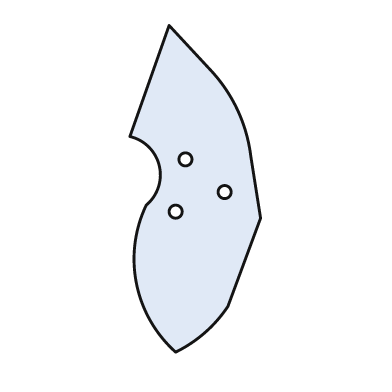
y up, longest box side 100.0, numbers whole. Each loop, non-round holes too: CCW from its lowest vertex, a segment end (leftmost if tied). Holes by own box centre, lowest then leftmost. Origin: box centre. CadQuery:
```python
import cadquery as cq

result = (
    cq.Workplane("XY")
    .moveTo(-6.0, -50.0)
    .threePointArc((3.0, -44.0), (10.0, -36.0))
    .lineTo(20.0, -9.0)
    .lineTo(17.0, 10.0)
    .threePointArc((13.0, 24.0), (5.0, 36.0))
    .lineTo(-8.0, 50.0)
    .lineTo(-20.0, 16.0)
    .threePointArc((-11.0, 7.0), (-15.0, -5.0))
    .threePointArc((-18.0, -29.0), (-6.0, -50.0))
    .close()
    .moveTo(-6.0, -7.0)
    .circle(2.0)
    .moveTo(9.0, -1.0)
    .circle(2.0)
    .moveTo(-3.0, 9.0)
    .circle(2.0)
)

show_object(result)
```